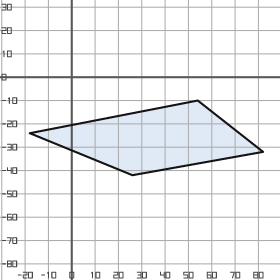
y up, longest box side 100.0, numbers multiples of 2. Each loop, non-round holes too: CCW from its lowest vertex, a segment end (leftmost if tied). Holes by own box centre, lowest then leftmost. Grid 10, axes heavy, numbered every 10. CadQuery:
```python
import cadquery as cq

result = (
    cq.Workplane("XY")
    .moveTo(26.0, -42.0)
    .lineTo(82.0, -32.0)
    .lineTo(54.0, -10.0)
    .lineTo(-18.0, -24.0)
    .close()
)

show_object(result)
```